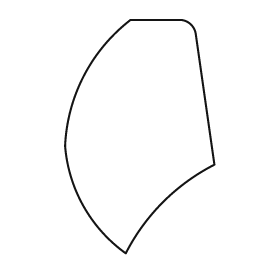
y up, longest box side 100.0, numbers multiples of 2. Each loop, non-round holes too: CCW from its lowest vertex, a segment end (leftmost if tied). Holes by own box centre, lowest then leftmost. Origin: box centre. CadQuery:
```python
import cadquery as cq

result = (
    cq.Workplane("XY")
    .moveTo(-6.0, -50.0)
    .threePointArc((10.0, -28.0), (32.0, -12.0))
    .lineTo(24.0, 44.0)
    .threePointArc((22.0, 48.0), (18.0, 50.0))
    .lineTo(-4.0, 50.0)
    .threePointArc((-24.0, 26.0), (-32.0, -4.0))
    .threePointArc((-24.0, -30.0), (-6.0, -50.0))
    .close()
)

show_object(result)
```